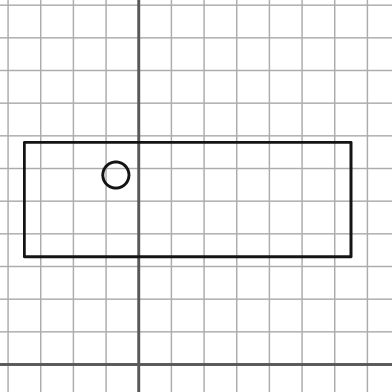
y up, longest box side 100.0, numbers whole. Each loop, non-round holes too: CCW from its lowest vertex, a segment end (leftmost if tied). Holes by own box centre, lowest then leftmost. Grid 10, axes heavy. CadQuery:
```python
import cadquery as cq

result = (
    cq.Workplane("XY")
    .moveTo(-35.0, 33.0)
    .lineTo(65.0, 33.0)
    .lineTo(65.0, 68.0)
    .lineTo(-35.0, 68.0)
    .close()
    .moveTo(-7.0, 58.0)
    .circle(4.0)
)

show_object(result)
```